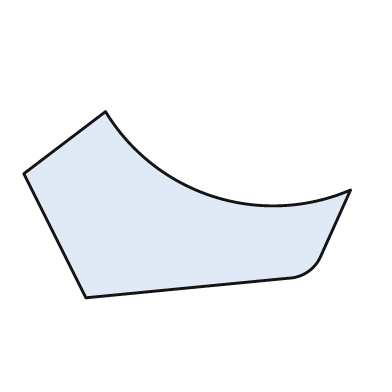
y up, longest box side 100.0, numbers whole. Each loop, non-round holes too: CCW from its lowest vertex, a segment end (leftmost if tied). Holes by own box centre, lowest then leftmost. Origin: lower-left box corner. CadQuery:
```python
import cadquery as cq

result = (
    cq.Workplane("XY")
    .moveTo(19.0, 0.0)
    .lineTo(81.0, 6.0)
    .threePointArc((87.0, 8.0), (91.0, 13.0))
    .lineTo(100.0, 33.0)
    .threePointArc((58.0, 31.0), (25.0, 57.0))
    .lineTo(0.0, 38.0)
    .close()
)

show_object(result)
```